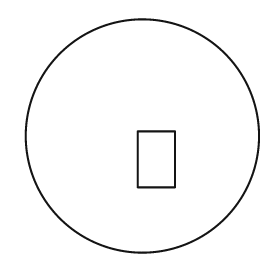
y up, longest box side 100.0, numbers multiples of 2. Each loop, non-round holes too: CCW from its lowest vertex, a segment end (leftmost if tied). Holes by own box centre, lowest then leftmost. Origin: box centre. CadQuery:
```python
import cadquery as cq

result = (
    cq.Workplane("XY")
    .moveTo(0.0, 0.0)
    .circle(50.0)
    .moveTo(-2.0, -22.0)
    .lineTo(14.0, -22.0)
    .lineTo(14.0, 2.0)
    .lineTo(-2.0, 2.0)
    .close()
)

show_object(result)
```